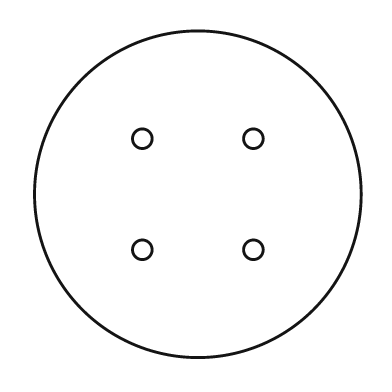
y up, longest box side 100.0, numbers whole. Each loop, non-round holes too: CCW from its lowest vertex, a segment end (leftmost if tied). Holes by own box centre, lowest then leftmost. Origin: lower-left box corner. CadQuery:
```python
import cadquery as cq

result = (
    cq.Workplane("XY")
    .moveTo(50.0, 50.0)
    .circle(50.0)
    .moveTo(33.0, 33.0)
    .circle(3.0)
    .moveTo(67.0, 33.0)
    .circle(3.0)
    .moveTo(33.0, 67.0)
    .circle(3.0)
    .moveTo(67.0, 67.0)
    .circle(3.0)
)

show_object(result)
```